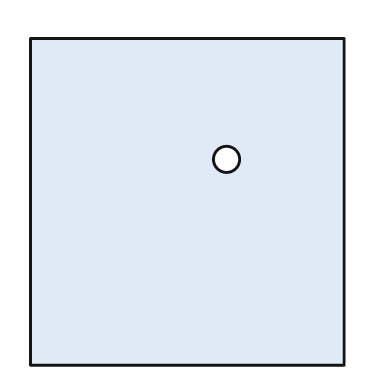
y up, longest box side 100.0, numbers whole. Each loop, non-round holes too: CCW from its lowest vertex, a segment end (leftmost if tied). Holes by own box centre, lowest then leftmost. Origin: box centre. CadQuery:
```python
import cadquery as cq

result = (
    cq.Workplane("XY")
    .moveTo(-48.0, -50.0)
    .lineTo(48.0, -50.0)
    .lineTo(48.0, 50.0)
    .lineTo(-48.0, 50.0)
    .close()
    .moveTo(12.0, 13.0)
    .circle(4.0)
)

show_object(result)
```